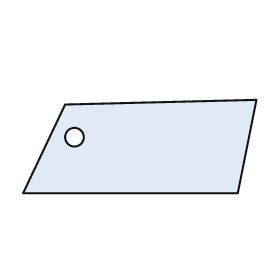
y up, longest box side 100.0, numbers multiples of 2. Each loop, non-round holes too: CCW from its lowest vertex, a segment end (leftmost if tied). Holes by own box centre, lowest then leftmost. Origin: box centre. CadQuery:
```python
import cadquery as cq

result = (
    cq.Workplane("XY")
    .moveTo(-50.0, -20.0)
    .lineTo(42.0, -20.0)
    .lineTo(50.0, 20.0)
    .lineTo(-32.0, 18.0)
    .close()
    .moveTo(-28.0, 4.0)
    .circle(4.0)
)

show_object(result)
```